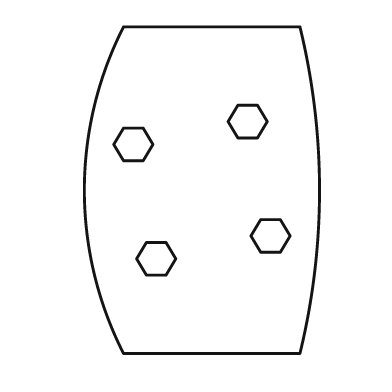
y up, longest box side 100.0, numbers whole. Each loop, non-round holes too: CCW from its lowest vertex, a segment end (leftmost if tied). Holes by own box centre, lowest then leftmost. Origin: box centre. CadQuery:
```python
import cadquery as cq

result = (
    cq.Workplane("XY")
    .moveTo(-24.0, -50.0)
    .lineTo(30.0, -50.0)
    .threePointArc((36.0, 0.0), (30.0, 50.0))
    .lineTo(-24.0, 50.0)
    .threePointArc((-36.0, 0.0), (-24.0, -50.0))
    .close()
    .moveTo(-17.0, -26.0)
    .lineTo(-11.0, -26.0)
    .lineTo(-8.0, -21.0)
    .lineTo(-11.0, -16.0)
    .lineTo(-17.0, -16.0)
    .lineTo(-20.0, -21.0)
    .close()
    .moveTo(18.0, -19.0)
    .lineTo(24.0, -19.0)
    .lineTo(27.0, -14.0)
    .lineTo(24.0, -9.0)
    .lineTo(18.0, -9.0)
    .lineTo(15.0, -14.0)
    .close()
    .moveTo(-24.0, 9.0)
    .lineTo(-18.0, 9.0)
    .lineTo(-15.0, 14.0)
    .lineTo(-18.0, 19.0)
    .lineTo(-24.0, 19.0)
    .lineTo(-27.0, 14.0)
    .close()
    .moveTo(11.0, 16.0)
    .lineTo(17.0, 16.0)
    .lineTo(20.0, 21.0)
    .lineTo(17.0, 26.0)
    .lineTo(11.0, 26.0)
    .lineTo(8.0, 21.0)
    .close()
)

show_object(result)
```